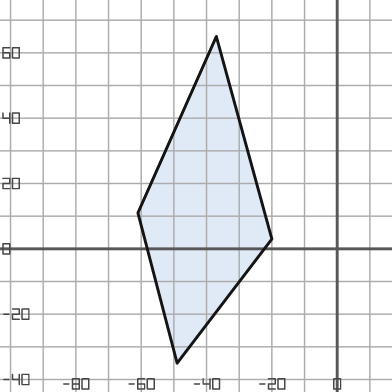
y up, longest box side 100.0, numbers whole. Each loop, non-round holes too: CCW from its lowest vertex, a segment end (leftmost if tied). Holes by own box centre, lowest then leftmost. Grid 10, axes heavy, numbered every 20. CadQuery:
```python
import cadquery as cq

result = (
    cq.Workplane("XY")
    .moveTo(-49.0, -35.0)
    .lineTo(-20.0, 3.0)
    .lineTo(-37.0, 65.0)
    .lineTo(-61.0, 11.0)
    .close()
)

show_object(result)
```